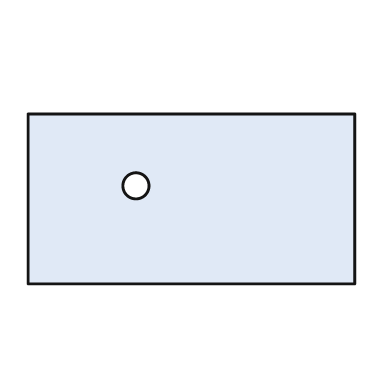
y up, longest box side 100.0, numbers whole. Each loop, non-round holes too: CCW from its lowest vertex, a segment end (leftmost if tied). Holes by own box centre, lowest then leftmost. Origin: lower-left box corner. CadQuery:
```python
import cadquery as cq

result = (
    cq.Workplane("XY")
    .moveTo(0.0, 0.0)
    .lineTo(100.0, 0.0)
    .lineTo(100.0, 52.0)
    .lineTo(0.0, 52.0)
    .close()
    .moveTo(33.0, 30.0)
    .circle(4.0)
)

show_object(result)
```